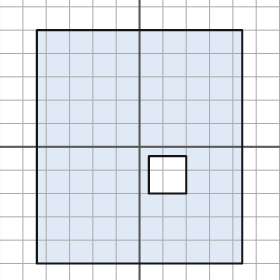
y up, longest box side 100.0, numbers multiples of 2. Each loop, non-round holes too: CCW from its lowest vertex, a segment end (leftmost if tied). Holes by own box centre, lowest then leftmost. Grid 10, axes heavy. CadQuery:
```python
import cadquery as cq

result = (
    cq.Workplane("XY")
    .moveTo(-44.0, -50.0)
    .lineTo(44.0, -50.0)
    .lineTo(44.0, 50.0)
    .lineTo(-44.0, 50.0)
    .close()
    .moveTo(4.0, -20.0)
    .lineTo(20.0, -20.0)
    .lineTo(20.0, -4.0)
    .lineTo(4.0, -4.0)
    .close()
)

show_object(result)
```